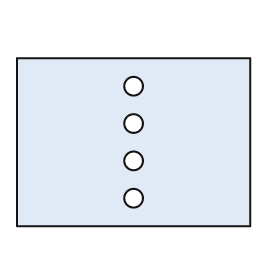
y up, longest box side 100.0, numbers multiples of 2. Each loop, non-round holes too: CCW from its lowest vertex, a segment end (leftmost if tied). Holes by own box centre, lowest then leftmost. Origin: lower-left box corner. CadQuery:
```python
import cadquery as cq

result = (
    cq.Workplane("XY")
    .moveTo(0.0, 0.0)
    .lineTo(100.0, 0.0)
    .lineTo(100.0, 72.0)
    .lineTo(0.0, 72.0)
    .close()
    .moveTo(50.0, 12.0)
    .circle(4.0)
    .moveTo(50.0, 28.0)
    .circle(4.0)
    .moveTo(50.0, 44.0)
    .circle(4.0)
    .moveTo(50.0, 60.0)
    .circle(4.0)
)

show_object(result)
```